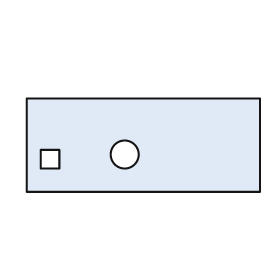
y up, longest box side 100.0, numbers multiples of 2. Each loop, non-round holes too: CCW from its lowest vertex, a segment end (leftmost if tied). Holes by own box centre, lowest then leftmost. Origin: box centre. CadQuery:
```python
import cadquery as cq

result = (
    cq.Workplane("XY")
    .moveTo(-50.0, -20.0)
    .lineTo(50.0, -20.0)
    .lineTo(50.0, 20.0)
    .lineTo(-50.0, 20.0)
    .close()
    .moveTo(-44.0, -10.0)
    .lineTo(-36.0, -10.0)
    .lineTo(-36.0, -2.0)
    .lineTo(-44.0, -2.0)
    .close()
    .moveTo(-8.0, -4.0)
    .circle(6.0)
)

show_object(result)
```